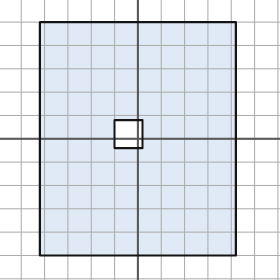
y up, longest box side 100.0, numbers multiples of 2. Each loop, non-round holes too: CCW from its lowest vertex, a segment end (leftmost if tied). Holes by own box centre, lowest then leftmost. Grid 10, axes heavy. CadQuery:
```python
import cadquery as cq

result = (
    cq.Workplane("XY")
    .moveTo(-42.0, -50.0)
    .lineTo(42.0, -50.0)
    .lineTo(42.0, 50.0)
    .lineTo(-42.0, 50.0)
    .close()
    .moveTo(-10.0, -4.0)
    .lineTo(2.0, -4.0)
    .lineTo(2.0, 8.0)
    .lineTo(-10.0, 8.0)
    .close()
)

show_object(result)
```